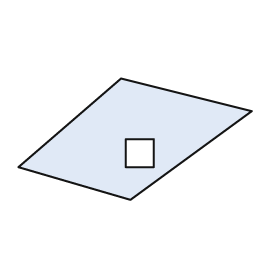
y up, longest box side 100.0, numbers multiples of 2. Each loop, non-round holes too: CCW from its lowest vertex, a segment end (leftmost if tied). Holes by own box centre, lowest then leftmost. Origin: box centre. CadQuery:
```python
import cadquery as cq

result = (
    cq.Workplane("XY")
    .moveTo(-2.0, -26.0)
    .lineTo(50.0, 12.0)
    .lineTo(-6.0, 26.0)
    .lineTo(-50.0, -12.0)
    .close()
    .moveTo(-4.0, -12.0)
    .lineTo(8.0, -12.0)
    .lineTo(8.0, 0.0)
    .lineTo(-4.0, 0.0)
    .close()
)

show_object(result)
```